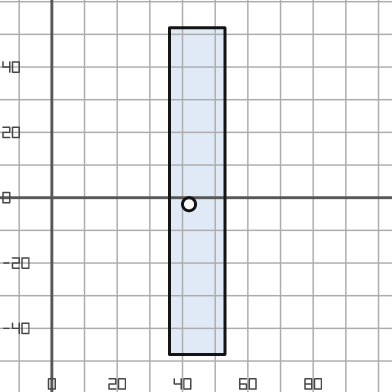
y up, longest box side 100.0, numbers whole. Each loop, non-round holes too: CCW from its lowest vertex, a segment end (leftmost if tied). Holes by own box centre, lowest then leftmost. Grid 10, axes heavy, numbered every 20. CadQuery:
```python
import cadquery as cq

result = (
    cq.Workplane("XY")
    .moveTo(36.0, -48.0)
    .lineTo(53.0, -48.0)
    .lineTo(53.0, 52.0)
    .lineTo(36.0, 52.0)
    .close()
    .moveTo(42.0, -2.0)
    .circle(2.0)
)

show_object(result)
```